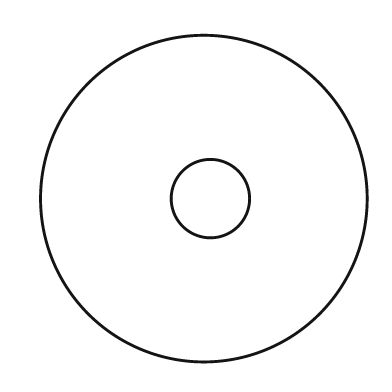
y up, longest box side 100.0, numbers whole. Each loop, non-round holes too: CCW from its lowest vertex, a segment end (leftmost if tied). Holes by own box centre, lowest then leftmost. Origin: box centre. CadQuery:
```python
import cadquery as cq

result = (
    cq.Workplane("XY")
    .moveTo(0.0, 0.0)
    .circle(50.0)
    .moveTo(2.0, 0.0)
    .circle(12.0)
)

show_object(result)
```